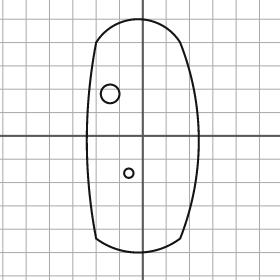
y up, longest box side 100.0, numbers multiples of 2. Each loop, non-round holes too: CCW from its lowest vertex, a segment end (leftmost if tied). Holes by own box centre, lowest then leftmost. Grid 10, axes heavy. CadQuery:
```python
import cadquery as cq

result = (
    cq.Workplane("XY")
    .moveTo(-20.0, -44.0)
    .threePointArc((-2.0, -50.0), (16.0, -44.0))
    .threePointArc((24.0, -2.0), (16.0, 40.0))
    .threePointArc((-2.0, 50.0), (-20.0, 40.0))
    .threePointArc((-24.0, -2.0), (-20.0, -44.0))
    .close()
    .moveTo(-6.0, -16.0)
    .circle(2.0)
    .moveTo(-14.0, 18.0)
    .circle(4.0)
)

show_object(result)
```